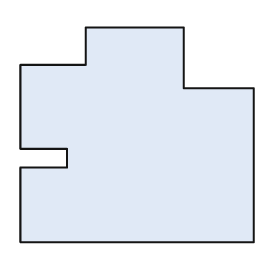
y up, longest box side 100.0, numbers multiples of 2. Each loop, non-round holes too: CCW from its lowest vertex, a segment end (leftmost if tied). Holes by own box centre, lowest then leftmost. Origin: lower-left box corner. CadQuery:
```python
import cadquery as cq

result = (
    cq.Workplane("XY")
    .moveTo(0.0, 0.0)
    .lineTo(100.0, 0.0)
    .lineTo(100.0, 66.0)
    .lineTo(70.0, 66.0)
    .lineTo(70.0, 92.0)
    .lineTo(28.0, 92.0)
    .lineTo(28.0, 76.0)
    .lineTo(0.0, 76.0)
    .lineTo(0.0, 40.0)
    .lineTo(20.0, 40.0)
    .lineTo(20.0, 32.0)
    .lineTo(0.0, 32.0)
    .close()
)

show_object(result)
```